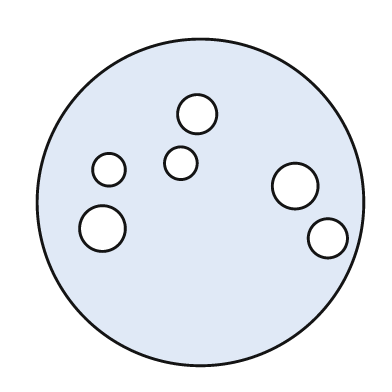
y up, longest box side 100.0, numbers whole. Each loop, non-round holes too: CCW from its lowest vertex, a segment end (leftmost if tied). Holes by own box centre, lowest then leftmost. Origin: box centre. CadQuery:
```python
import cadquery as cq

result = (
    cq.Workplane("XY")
    .moveTo(0.0, 0.0)
    .circle(50.0)
    .moveTo(39.0, -11.0)
    .circle(6.0)
    .moveTo(-30.0, -8.0)
    .circle(7.0)
    .moveTo(29.0, 5.0)
    .circle(7.0)
    .moveTo(-28.0, 10.0)
    .circle(5.0)
    .moveTo(-6.0, 12.0)
    .circle(5.0)
    .moveTo(-1.0, 27.0)
    .circle(6.0)
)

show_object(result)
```